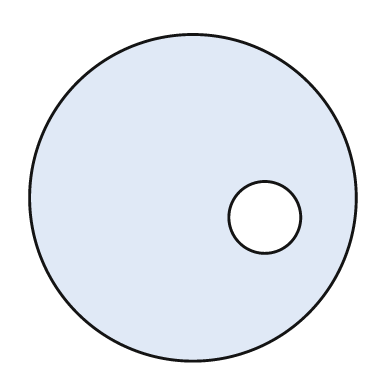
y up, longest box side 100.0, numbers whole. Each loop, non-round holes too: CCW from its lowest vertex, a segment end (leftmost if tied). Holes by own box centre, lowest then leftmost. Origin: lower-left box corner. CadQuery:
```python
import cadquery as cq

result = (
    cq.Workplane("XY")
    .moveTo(50.0, 50.0)
    .circle(50.0)
    .moveTo(72.0, 44.0)
    .circle(11.0)
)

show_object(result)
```